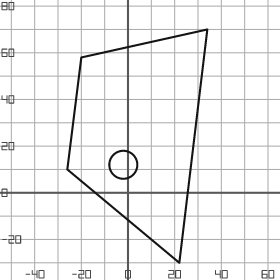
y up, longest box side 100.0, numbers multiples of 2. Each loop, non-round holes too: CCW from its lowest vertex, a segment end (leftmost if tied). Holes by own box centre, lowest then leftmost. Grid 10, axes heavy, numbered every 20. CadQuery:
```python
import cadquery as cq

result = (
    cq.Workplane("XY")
    .moveTo(22.0, -30.0)
    .lineTo(34.0, 70.0)
    .lineTo(-20.0, 58.0)
    .lineTo(-26.0, 10.0)
    .close()
    .moveTo(-2.0, 12.0)
    .circle(6.0)
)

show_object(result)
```